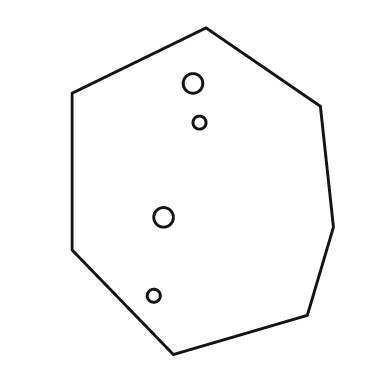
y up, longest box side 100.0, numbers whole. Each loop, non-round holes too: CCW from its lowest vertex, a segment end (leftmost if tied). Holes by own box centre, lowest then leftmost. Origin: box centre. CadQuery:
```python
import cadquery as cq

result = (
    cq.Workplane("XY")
    .moveTo(-9.0, -50.0)
    .lineTo(32.0, -38.0)
    .lineTo(40.0, -11.0)
    .lineTo(36.0, 26.0)
    .lineTo(1.0, 50.0)
    .lineTo(-40.0, 30.0)
    .lineTo(-40.0, -18.0)
    .close()
    .moveTo(-15.0, -32.0)
    .circle(2.0)
    .moveTo(-12.0, -8.0)
    .circle(3.0)
    .moveTo(-1.0, 21.0)
    .circle(2.0)
    .moveTo(-3.0, 33.0)
    .circle(3.0)
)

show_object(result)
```